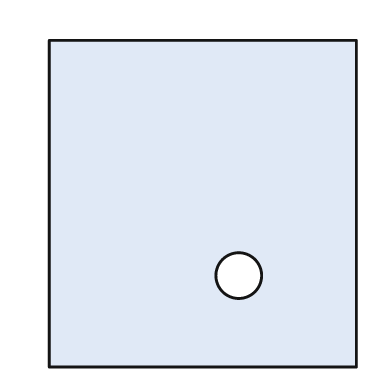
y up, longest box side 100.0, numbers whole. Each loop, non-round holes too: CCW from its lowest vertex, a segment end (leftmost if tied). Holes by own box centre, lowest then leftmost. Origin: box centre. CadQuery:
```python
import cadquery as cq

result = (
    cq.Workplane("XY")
    .moveTo(-47.0, -50.0)
    .lineTo(47.0, -50.0)
    .lineTo(47.0, 50.0)
    .lineTo(-47.0, 50.0)
    .close()
    .moveTo(11.0, -22.0)
    .circle(7.0)
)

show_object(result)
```